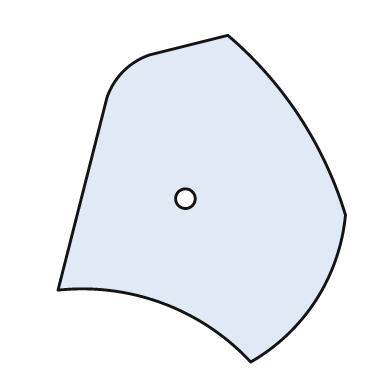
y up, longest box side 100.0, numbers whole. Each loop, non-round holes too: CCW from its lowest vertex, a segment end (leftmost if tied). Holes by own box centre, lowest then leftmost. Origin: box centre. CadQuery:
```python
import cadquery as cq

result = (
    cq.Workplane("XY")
    .moveTo(15.0, -50.0)
    .threePointArc((35.0, -31.0), (44.0, -5.0))
    .threePointArc((30.0, 25.0), (8.0, 50.0))
    .lineTo(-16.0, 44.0)
    .threePointArc((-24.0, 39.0), (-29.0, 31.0))
    .lineTo(-44.0, -28.0)
    .threePointArc((-12.0, -32.0), (15.0, -50.0))
    .close()
    .moveTo(-5.0, 0.0)
    .circle(3.0)
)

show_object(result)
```